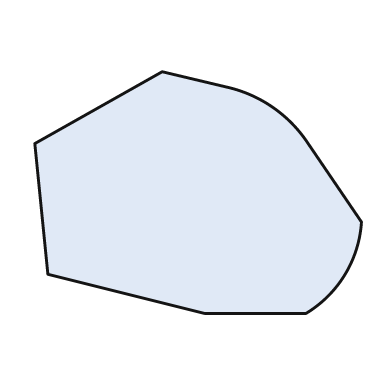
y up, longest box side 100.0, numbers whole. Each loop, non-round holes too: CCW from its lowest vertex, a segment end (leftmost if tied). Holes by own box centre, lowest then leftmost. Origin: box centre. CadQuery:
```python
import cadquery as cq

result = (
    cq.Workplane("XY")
    .moveTo(2.0, -37.0)
    .lineTo(33.0, -37.0)
    .threePointArc((45.0, -25.0), (50.0, -9.0))
    .lineTo(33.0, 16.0)
    .threePointArc((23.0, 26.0), (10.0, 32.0))
    .lineTo(-11.0, 37.0)
    .lineTo(-50.0, 15.0)
    .lineTo(-46.0, -25.0)
    .close()
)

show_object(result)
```